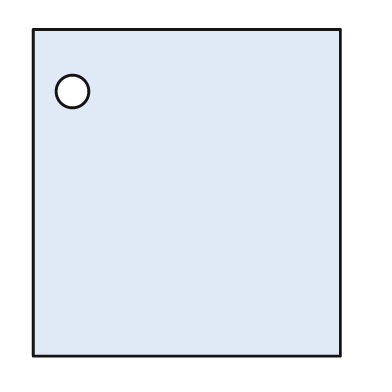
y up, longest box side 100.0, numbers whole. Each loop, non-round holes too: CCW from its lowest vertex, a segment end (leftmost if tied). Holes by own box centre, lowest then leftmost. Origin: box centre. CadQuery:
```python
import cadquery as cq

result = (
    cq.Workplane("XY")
    .moveTo(-47.0, -50.0)
    .lineTo(47.0, -50.0)
    .lineTo(47.0, 50.0)
    .lineTo(-47.0, 50.0)
    .close()
    .moveTo(-35.0, 31.0)
    .circle(5.0)
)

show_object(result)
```